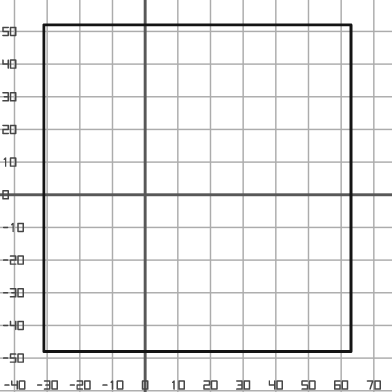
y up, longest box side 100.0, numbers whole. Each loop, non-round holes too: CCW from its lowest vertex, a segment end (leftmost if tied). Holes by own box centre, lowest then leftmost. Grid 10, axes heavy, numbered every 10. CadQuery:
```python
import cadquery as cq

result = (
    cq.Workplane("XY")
    .moveTo(-31.0, -48.0)
    .lineTo(63.0, -48.0)
    .lineTo(63.0, 52.0)
    .lineTo(-31.0, 52.0)
    .close()
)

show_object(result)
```